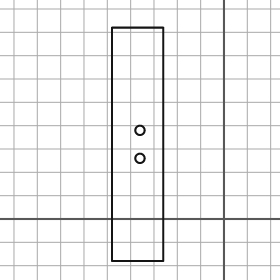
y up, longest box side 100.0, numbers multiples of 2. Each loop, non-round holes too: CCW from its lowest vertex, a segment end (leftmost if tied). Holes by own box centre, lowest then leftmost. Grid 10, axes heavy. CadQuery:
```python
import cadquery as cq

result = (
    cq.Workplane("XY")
    .moveTo(-48.0, -18.0)
    .lineTo(-26.0, -18.0)
    .lineTo(-26.0, 82.0)
    .lineTo(-48.0, 82.0)
    .close()
    .moveTo(-36.0, 26.0)
    .circle(2.0)
    .moveTo(-36.0, 38.0)
    .circle(2.0)
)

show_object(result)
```